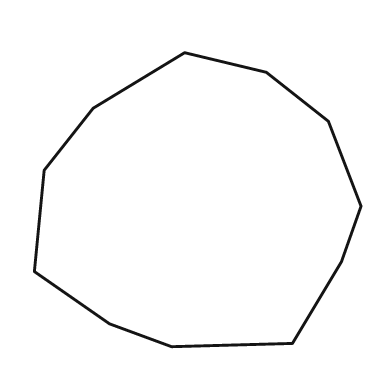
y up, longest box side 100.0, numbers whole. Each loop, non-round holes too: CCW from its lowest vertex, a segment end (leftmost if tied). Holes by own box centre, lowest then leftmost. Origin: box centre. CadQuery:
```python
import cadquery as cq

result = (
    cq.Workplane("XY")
    .moveTo(-8.0, -45.0)
    .lineTo(29.0, -44.0)
    .lineTo(44.0, -19.0)
    .lineTo(50.0, -2.0)
    .lineTo(40.0, 24.0)
    .lineTo(21.0, 39.0)
    .lineTo(-4.0, 45.0)
    .lineTo(-32.0, 28.0)
    .lineTo(-47.0, 9.0)
    .lineTo(-50.0, -22.0)
    .lineTo(-27.0, -38.0)
    .close()
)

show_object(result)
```